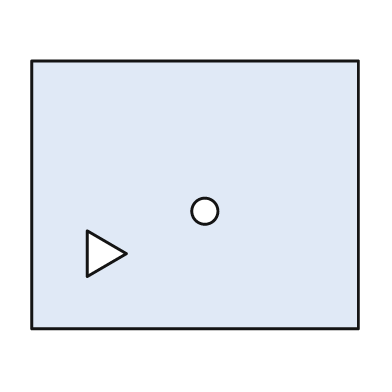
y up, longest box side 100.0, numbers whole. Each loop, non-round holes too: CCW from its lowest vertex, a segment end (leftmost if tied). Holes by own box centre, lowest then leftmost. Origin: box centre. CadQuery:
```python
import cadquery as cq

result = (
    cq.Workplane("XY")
    .moveTo(-50.0, -41.0)
    .lineTo(50.0, -41.0)
    .lineTo(50.0, 41.0)
    .lineTo(-50.0, 41.0)
    .close()
    .moveTo(-33.0, -25.0)
    .lineTo(-21.0, -18.0)
    .lineTo(-33.0, -11.0)
    .close()
    .moveTo(3.0, -5.0)
    .circle(4.0)
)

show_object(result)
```